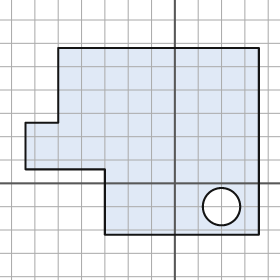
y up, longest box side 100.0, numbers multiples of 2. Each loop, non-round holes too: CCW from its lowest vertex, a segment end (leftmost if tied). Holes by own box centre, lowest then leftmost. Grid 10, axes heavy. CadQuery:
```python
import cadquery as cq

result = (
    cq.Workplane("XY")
    .moveTo(-30.0, -22.0)
    .lineTo(36.0, -22.0)
    .lineTo(36.0, 58.0)
    .lineTo(-50.0, 58.0)
    .lineTo(-50.0, 26.0)
    .lineTo(-64.0, 26.0)
    .lineTo(-64.0, 6.0)
    .lineTo(-30.0, 6.0)
    .close()
    .moveTo(20.0, -10.0)
    .circle(8.0)
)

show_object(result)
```